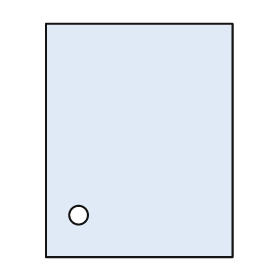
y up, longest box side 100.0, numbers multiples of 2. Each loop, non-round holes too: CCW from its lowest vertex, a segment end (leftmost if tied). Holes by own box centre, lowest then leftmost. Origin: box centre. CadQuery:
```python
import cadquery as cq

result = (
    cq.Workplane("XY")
    .moveTo(-40.0, -50.0)
    .lineTo(40.0, -50.0)
    .lineTo(40.0, 50.0)
    .lineTo(-40.0, 50.0)
    .close()
    .moveTo(-26.0, -32.0)
    .circle(4.0)
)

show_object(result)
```